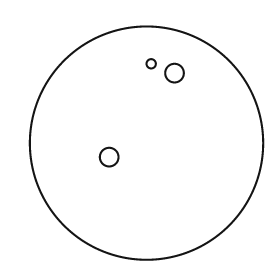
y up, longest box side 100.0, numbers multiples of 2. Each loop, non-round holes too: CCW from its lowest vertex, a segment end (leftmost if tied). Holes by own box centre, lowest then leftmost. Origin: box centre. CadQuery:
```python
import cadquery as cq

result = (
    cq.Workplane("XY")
    .moveTo(0.0, 0.0)
    .circle(50.0)
    .moveTo(-16.0, -6.0)
    .circle(4.0)
    .moveTo(12.0, 30.0)
    .circle(4.0)
    .moveTo(2.0, 34.0)
    .circle(2.0)
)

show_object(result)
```